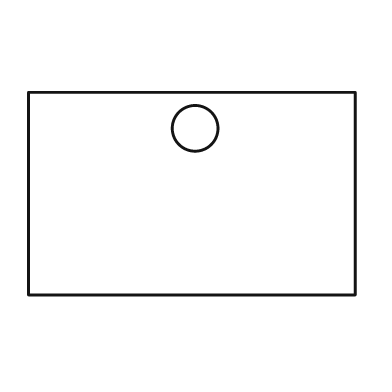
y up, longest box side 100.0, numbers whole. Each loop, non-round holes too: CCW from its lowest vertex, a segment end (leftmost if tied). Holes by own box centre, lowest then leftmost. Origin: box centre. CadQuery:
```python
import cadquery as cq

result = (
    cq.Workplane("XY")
    .moveTo(-50.0, -31.0)
    .lineTo(50.0, -31.0)
    .lineTo(50.0, 31.0)
    .lineTo(-50.0, 31.0)
    .close()
    .moveTo(1.0, 20.0)
    .circle(7.0)
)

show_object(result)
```